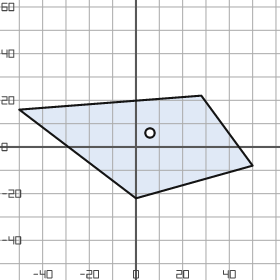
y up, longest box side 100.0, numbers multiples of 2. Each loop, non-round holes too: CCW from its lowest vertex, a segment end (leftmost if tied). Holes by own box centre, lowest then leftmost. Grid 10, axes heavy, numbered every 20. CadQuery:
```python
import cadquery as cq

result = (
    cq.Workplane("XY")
    .moveTo(0.0, -22.0)
    .lineTo(50.0, -8.0)
    .lineTo(28.0, 22.0)
    .lineTo(-50.0, 16.0)
    .close()
    .moveTo(6.0, 6.0)
    .circle(2.0)
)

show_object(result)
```